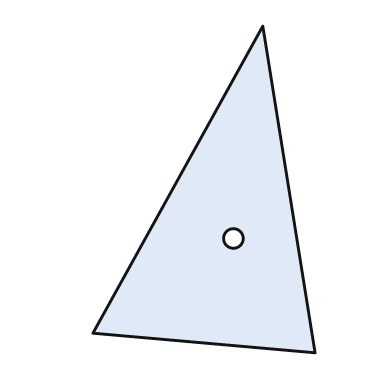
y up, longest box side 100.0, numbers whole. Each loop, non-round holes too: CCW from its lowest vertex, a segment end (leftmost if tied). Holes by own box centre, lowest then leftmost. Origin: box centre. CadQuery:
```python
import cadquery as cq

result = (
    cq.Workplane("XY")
    .moveTo(34.0, -50.0)
    .lineTo(18.0, 50.0)
    .lineTo(-34.0, -44.0)
    .close()
    .moveTo(9.0, -15.0)
    .circle(3.0)
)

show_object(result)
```